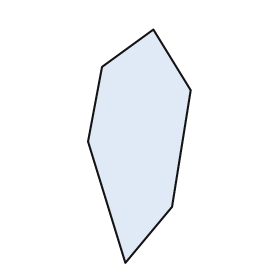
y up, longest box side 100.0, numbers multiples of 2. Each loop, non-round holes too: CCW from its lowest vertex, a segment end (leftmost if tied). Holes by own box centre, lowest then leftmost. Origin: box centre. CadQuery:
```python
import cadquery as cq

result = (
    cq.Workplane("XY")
    .moveTo(-6.0, -50.0)
    .lineTo(14.0, -26.0)
    .lineTo(22.0, 24.0)
    .lineTo(6.0, 50.0)
    .lineTo(-16.0, 34.0)
    .lineTo(-22.0, 2.0)
    .close()
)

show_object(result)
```